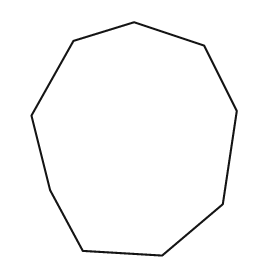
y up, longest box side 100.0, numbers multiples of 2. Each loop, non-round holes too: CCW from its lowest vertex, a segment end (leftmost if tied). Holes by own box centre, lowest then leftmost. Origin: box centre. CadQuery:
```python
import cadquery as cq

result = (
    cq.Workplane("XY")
    .moveTo(12.0, -50.0)
    .lineTo(38.0, -28.0)
    .lineTo(44.0, 12.0)
    .lineTo(30.0, 40.0)
    .lineTo(0.0, 50.0)
    .lineTo(-26.0, 42.0)
    .lineTo(-44.0, 10.0)
    .lineTo(-36.0, -22.0)
    .lineTo(-22.0, -48.0)
    .close()
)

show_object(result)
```